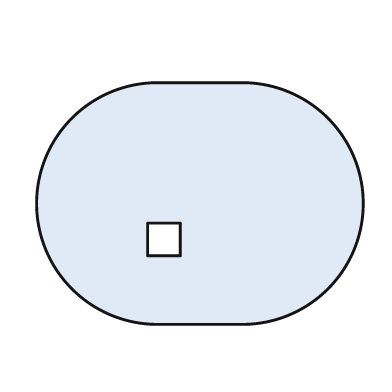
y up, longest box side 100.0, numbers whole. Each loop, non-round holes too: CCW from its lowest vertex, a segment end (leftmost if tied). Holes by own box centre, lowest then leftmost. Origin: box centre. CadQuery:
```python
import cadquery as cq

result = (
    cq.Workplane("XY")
    .moveTo(-13.0, -37.0)
    .lineTo(13.0, -37.0)
    .threePointArc((50.0, 0.0), (13.0, 37.0))
    .lineTo(-13.0, 37.0)
    .threePointArc((-50.0, 0.0), (-13.0, -37.0))
    .close()
    .moveTo(-16.0, -16.0)
    .lineTo(-6.0, -16.0)
    .lineTo(-6.0, -6.0)
    .lineTo(-16.0, -6.0)
    .close()
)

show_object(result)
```